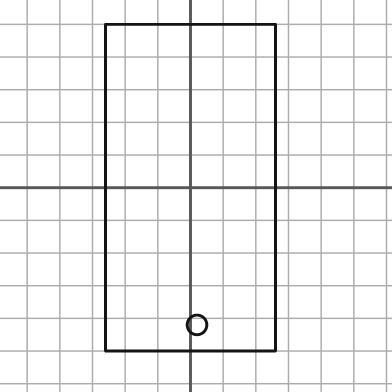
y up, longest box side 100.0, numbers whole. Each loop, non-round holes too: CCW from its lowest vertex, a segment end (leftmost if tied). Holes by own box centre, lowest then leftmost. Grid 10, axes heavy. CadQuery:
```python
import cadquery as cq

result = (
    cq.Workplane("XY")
    .moveTo(-26.0, -50.0)
    .lineTo(26.0, -50.0)
    .lineTo(26.0, 50.0)
    .lineTo(-26.0, 50.0)
    .close()
    .moveTo(2.0, -42.0)
    .circle(3.0)
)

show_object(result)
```